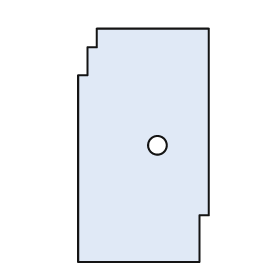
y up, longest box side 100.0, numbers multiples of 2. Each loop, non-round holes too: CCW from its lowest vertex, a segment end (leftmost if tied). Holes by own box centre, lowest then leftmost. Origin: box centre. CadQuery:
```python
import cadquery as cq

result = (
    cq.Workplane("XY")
    .moveTo(-28.0, -50.0)
    .lineTo(24.0, -50.0)
    .lineTo(24.0, -30.0)
    .lineTo(28.0, -30.0)
    .lineTo(28.0, 50.0)
    .lineTo(-20.0, 50.0)
    .lineTo(-20.0, 42.0)
    .lineTo(-24.0, 42.0)
    .lineTo(-24.0, 30.0)
    .lineTo(-28.0, 30.0)
    .close()
    .moveTo(6.0, 0.0)
    .circle(4.0)
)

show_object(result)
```